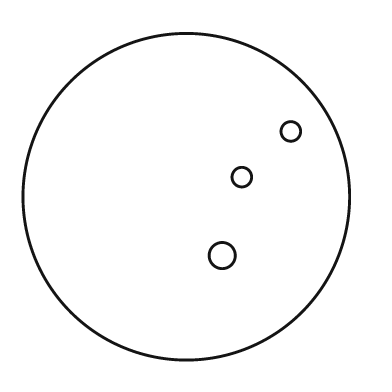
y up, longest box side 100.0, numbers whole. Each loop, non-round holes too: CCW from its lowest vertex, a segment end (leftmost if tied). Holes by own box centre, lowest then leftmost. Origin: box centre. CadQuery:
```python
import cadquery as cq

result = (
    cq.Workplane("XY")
    .moveTo(0.0, 0.0)
    .circle(50.0)
    .moveTo(11.0, -18.0)
    .circle(4.0)
    .moveTo(17.0, 6.0)
    .circle(3.0)
    .moveTo(32.0, 20.0)
    .circle(3.0)
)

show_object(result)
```